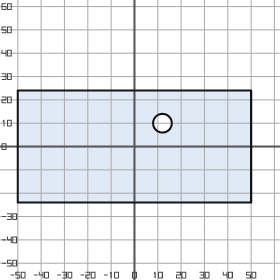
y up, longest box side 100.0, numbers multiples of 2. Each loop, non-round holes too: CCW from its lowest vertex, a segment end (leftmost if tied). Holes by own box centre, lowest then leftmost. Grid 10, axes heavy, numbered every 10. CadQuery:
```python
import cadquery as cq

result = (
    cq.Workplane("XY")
    .moveTo(-50.0, -24.0)
    .lineTo(50.0, -24.0)
    .lineTo(50.0, 24.0)
    .lineTo(-50.0, 24.0)
    .close()
    .moveTo(12.0, 10.0)
    .circle(4.0)
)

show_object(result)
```